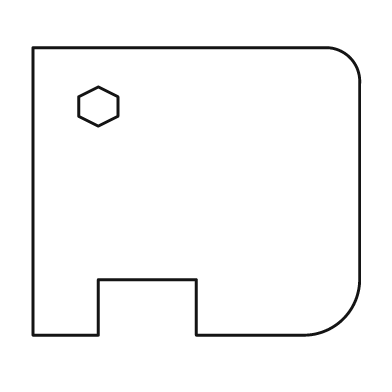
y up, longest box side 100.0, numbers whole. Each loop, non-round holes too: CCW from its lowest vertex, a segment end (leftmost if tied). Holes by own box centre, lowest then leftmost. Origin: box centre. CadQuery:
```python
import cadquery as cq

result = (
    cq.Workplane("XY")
    .moveTo(-50.0, -44.0)
    .lineTo(-30.0, -44.0)
    .lineTo(-30.0, -27.0)
    .lineTo(0.0, -27.0)
    .lineTo(0.0, -44.0)
    .lineTo(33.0, -44.0)
    .threePointArc((45.0, -39.0), (50.0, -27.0))
    .lineTo(50.0, 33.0)
    .threePointArc((47.0, 41.0), (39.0, 44.0))
    .lineTo(-50.0, 44.0)
    .close()
    .moveTo(-30.0, 20.0)
    .lineTo(-24.0, 23.0)
    .lineTo(-24.0, 29.0)
    .lineTo(-30.0, 32.0)
    .lineTo(-36.0, 29.0)
    .lineTo(-36.0, 23.0)
    .close()
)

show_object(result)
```